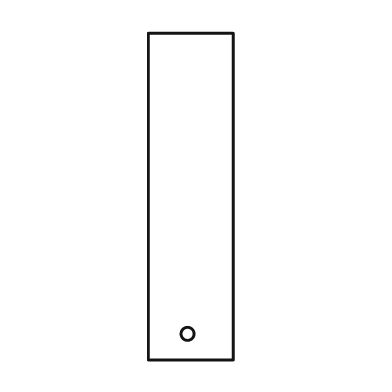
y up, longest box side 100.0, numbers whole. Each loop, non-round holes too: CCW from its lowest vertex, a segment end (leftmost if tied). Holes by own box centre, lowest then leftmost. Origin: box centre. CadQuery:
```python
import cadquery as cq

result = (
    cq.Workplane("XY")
    .moveTo(-13.0, -50.0)
    .lineTo(13.0, -50.0)
    .lineTo(13.0, 50.0)
    .lineTo(-13.0, 50.0)
    .close()
    .moveTo(-1.0, -42.0)
    .circle(2.0)
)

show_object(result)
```